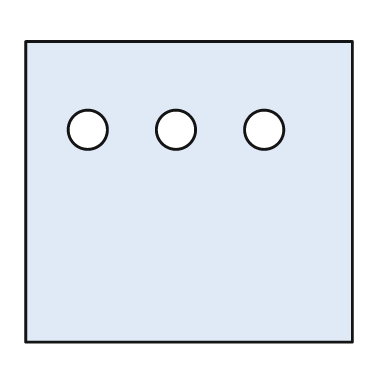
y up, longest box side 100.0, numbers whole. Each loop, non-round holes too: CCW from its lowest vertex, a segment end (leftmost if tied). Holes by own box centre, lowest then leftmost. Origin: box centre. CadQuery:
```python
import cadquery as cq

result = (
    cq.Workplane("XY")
    .moveTo(-50.0, -46.0)
    .lineTo(50.0, -46.0)
    .lineTo(50.0, 46.0)
    .lineTo(-50.0, 46.0)
    .close()
    .moveTo(-31.0, 19.0)
    .circle(6.0)
    .moveTo(-4.0, 19.0)
    .circle(6.0)
    .moveTo(23.0, 19.0)
    .circle(6.0)
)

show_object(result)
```